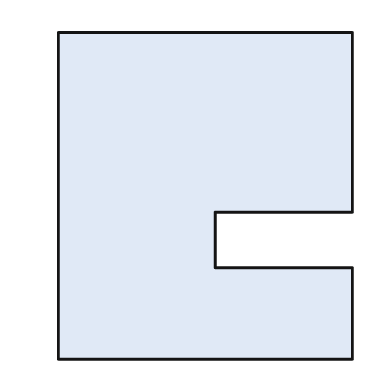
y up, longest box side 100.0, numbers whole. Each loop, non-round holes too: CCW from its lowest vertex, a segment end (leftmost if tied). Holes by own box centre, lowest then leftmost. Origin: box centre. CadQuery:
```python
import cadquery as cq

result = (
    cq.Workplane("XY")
    .moveTo(-45.0, -50.0)
    .lineTo(45.0, -50.0)
    .lineTo(45.0, -22.0)
    .lineTo(3.0, -22.0)
    .lineTo(3.0, -5.0)
    .lineTo(45.0, -5.0)
    .lineTo(45.0, 50.0)
    .lineTo(-45.0, 50.0)
    .close()
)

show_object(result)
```